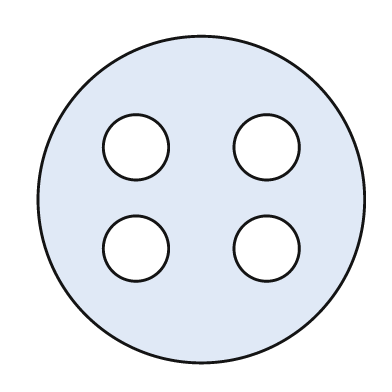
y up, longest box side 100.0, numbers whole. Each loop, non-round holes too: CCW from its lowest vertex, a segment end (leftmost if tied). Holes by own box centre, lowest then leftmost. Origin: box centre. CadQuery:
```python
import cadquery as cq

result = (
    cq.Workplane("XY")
    .moveTo(0.0, 0.0)
    .circle(50.0)
    .moveTo(-20.0, -15.0)
    .circle(10.0)
    .moveTo(20.0, -15.0)
    .circle(10.0)
    .moveTo(-20.0, 16.0)
    .circle(10.0)
    .moveTo(20.0, 16.0)
    .circle(10.0)
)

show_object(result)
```